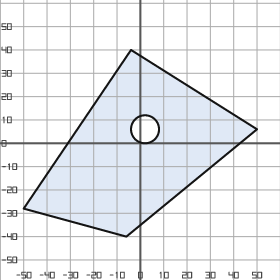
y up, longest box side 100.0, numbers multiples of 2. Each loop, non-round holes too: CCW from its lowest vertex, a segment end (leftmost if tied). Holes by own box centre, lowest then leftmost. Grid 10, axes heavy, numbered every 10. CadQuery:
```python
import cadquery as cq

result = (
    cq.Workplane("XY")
    .moveTo(-6.0, -40.0)
    .lineTo(50.0, 6.0)
    .lineTo(-4.0, 40.0)
    .lineTo(-50.0, -28.0)
    .close()
    .moveTo(2.0, 6.0)
    .circle(6.0)
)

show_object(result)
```